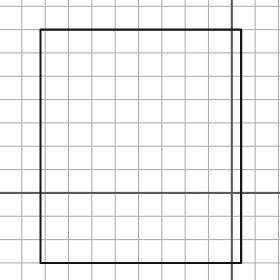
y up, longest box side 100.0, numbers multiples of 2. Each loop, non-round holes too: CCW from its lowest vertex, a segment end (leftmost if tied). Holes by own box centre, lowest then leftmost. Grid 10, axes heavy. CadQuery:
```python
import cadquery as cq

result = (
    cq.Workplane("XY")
    .moveTo(-82.0, -30.0)
    .lineTo(4.0, -30.0)
    .lineTo(4.0, 70.0)
    .lineTo(-82.0, 70.0)
    .close()
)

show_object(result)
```